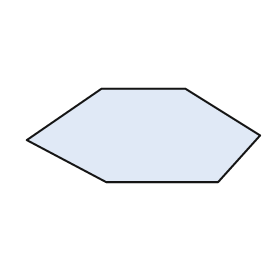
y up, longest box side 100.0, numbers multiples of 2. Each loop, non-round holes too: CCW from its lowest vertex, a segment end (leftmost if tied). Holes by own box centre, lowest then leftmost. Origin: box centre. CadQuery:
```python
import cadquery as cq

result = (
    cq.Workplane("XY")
    .moveTo(-16.0, -20.0)
    .lineTo(32.0, -20.0)
    .lineTo(50.0, 0.0)
    .lineTo(18.0, 20.0)
    .lineTo(-18.0, 20.0)
    .lineTo(-50.0, -2.0)
    .close()
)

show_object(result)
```